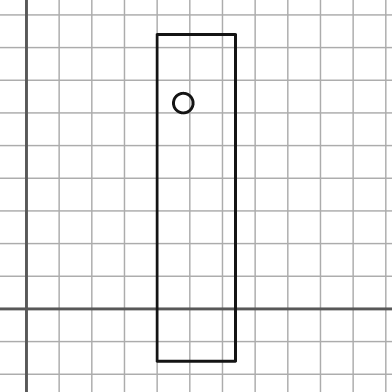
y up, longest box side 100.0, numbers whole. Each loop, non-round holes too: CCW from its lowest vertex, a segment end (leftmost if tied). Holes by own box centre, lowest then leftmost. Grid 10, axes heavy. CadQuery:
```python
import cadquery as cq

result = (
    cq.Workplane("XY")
    .moveTo(40.0, -16.0)
    .lineTo(64.0, -16.0)
    .lineTo(64.0, 84.0)
    .lineTo(40.0, 84.0)
    .close()
    .moveTo(48.0, 63.0)
    .circle(3.0)
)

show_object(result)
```